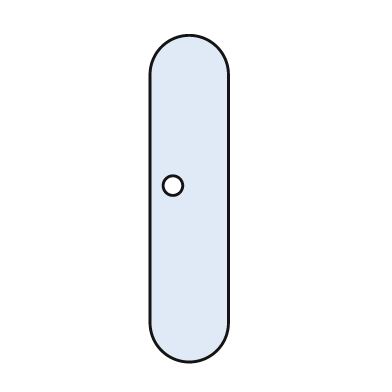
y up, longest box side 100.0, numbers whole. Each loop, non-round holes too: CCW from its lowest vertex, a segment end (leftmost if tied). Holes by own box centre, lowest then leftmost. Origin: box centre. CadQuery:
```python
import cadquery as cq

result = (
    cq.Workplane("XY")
    .moveTo(-12.0, -38.0)
    .threePointArc((0.0, -50.0), (12.0, -38.0))
    .lineTo(12.0, 38.0)
    .threePointArc((0.0, 50.0), (-12.0, 38.0))
    .close()
    .moveTo(-5.0, 4.0)
    .circle(3.0)
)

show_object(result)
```